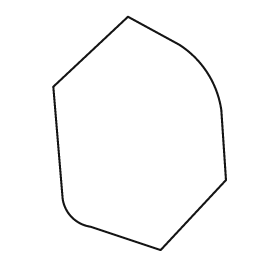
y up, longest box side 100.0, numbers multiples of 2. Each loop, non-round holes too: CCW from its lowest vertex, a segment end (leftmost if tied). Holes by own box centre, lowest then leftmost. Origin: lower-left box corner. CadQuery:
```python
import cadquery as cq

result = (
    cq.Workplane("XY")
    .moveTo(46.0, 0.0)
    .lineTo(74.0, 30.0)
    .lineTo(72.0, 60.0)
    .threePointArc((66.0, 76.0), (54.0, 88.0))
    .lineTo(32.0, 100.0)
    .lineTo(0.0, 70.0)
    .lineTo(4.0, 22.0)
    .threePointArc((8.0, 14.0), (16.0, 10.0))
    .close()
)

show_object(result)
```